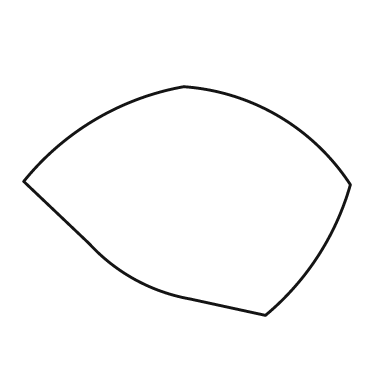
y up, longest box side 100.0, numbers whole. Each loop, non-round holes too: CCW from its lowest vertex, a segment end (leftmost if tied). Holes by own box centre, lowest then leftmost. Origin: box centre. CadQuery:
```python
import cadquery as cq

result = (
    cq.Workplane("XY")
    .moveTo(24.0, -35.0)
    .threePointArc((40.0, -17.0), (50.0, 5.0))
    .threePointArc((28.0, 26.0), (-1.0, 35.0))
    .threePointArc((-28.0, 25.0), (-50.0, 6.0))
    .lineTo(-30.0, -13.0)
    .threePointArc((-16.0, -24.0), (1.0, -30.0))
    .close()
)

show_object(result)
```